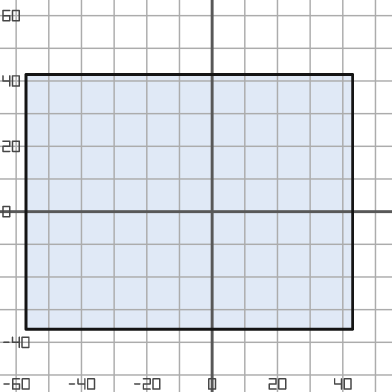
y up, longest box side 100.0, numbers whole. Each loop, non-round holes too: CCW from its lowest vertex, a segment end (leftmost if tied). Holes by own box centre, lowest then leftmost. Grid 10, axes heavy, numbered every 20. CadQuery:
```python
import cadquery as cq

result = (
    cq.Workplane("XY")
    .moveTo(-57.0, -36.0)
    .lineTo(43.0, -36.0)
    .lineTo(43.0, 42.0)
    .lineTo(-57.0, 42.0)
    .close()
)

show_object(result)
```